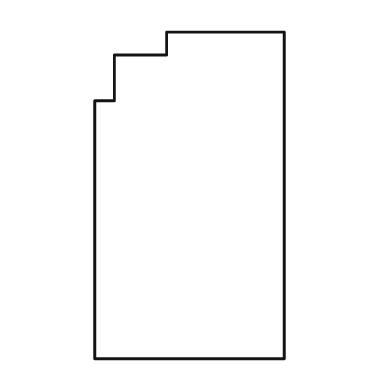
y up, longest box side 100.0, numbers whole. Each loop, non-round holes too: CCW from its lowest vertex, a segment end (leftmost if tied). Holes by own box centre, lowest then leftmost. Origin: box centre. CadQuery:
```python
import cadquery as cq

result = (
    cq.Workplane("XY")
    .moveTo(-29.0, -50.0)
    .lineTo(29.0, -50.0)
    .lineTo(29.0, 50.0)
    .lineTo(-7.0, 50.0)
    .lineTo(-7.0, 43.0)
    .lineTo(-23.0, 43.0)
    .lineTo(-23.0, 29.0)
    .lineTo(-29.0, 29.0)
    .close()
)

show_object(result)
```